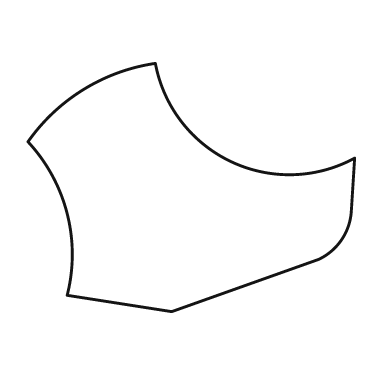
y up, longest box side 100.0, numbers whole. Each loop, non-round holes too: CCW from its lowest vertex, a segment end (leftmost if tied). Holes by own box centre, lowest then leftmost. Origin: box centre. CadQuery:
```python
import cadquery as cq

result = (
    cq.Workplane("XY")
    .moveTo(-6.0, -38.0)
    .lineTo(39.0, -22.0)
    .threePointArc((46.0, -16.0), (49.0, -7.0))
    .lineTo(50.0, 9.0)
    .threePointArc((12.0, 8.0), (-11.0, 38.0))
    .threePointArc((-33.0, 30.0), (-50.0, 14.0))
    .threePointArc((-38.0, -8.0), (-38.0, -33.0))
    .close()
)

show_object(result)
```